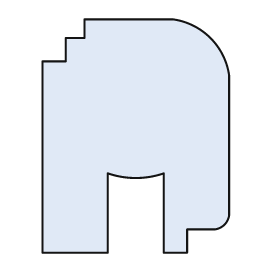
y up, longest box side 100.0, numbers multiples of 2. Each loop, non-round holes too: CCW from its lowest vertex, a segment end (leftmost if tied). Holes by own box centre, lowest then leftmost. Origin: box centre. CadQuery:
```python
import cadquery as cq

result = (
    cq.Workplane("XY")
    .moveTo(-40.0, -50.0)
    .lineTo(-12.0, -50.0)
    .lineTo(-12.0, -16.0)
    .threePointArc((0.0, -18.0), (12.0, -16.0))
    .lineTo(12.0, -50.0)
    .lineTo(22.0, -50.0)
    .lineTo(22.0, -40.0)
    .lineTo(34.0, -40.0)
    .threePointArc((38.0, -38.0), (40.0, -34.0))
    .lineTo(40.0, 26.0)
    .threePointArc((32.0, 42.0), (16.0, 50.0))
    .lineTo(-22.0, 50.0)
    .lineTo(-22.0, 42.0)
    .lineTo(-30.0, 42.0)
    .lineTo(-30.0, 32.0)
    .lineTo(-40.0, 32.0)
    .close()
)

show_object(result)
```